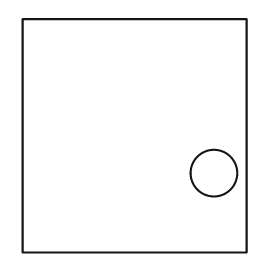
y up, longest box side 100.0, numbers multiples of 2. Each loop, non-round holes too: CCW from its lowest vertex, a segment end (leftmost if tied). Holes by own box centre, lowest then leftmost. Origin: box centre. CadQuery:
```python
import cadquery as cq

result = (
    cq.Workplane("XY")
    .moveTo(-48.0, -50.0)
    .lineTo(48.0, -50.0)
    .lineTo(48.0, 50.0)
    .lineTo(-48.0, 50.0)
    .close()
    .moveTo(34.0, -16.0)
    .circle(10.0)
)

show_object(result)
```